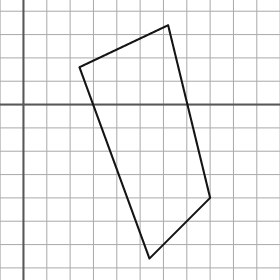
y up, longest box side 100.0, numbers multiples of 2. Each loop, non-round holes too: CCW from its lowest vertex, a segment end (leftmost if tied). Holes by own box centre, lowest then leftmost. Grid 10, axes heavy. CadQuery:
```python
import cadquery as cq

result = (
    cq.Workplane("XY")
    .moveTo(54.0, -66.0)
    .lineTo(80.0, -40.0)
    .lineTo(62.0, 34.0)
    .lineTo(24.0, 16.0)
    .close()
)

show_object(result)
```